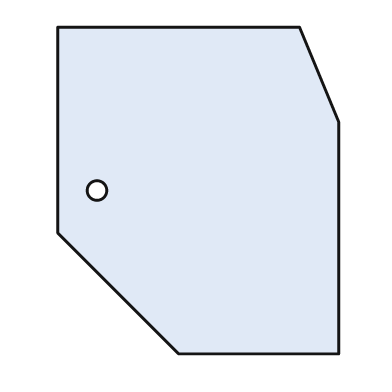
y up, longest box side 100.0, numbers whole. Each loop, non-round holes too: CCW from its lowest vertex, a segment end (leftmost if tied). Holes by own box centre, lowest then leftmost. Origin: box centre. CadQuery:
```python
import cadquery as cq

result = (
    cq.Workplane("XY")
    .moveTo(-6.0, -50.0)
    .lineTo(43.0, -50.0)
    .lineTo(43.0, 21.0)
    .lineTo(31.0, 50.0)
    .lineTo(-43.0, 50.0)
    .lineTo(-43.0, -13.0)
    .close()
    .moveTo(-31.0, 0.0)
    .circle(3.0)
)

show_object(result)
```